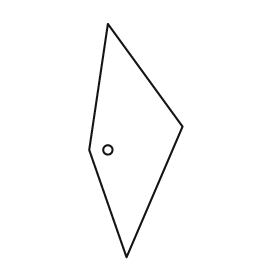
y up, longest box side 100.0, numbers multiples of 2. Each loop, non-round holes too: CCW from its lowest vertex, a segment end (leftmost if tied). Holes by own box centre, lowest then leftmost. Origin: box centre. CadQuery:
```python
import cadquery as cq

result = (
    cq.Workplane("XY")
    .moveTo(-4.0, -50.0)
    .lineTo(20.0, 6.0)
    .lineTo(-12.0, 50.0)
    .lineTo(-20.0, -4.0)
    .close()
    .moveTo(-12.0, -4.0)
    .circle(2.0)
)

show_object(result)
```